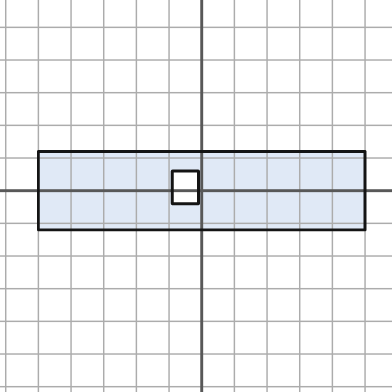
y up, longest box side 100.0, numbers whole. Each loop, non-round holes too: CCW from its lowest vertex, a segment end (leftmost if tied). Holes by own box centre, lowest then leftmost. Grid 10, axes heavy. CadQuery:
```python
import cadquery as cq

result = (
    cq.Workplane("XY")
    .moveTo(-50.0, -12.0)
    .lineTo(50.0, -12.0)
    .lineTo(50.0, 12.0)
    .lineTo(-50.0, 12.0)
    .close()
    .moveTo(-9.0, -4.0)
    .lineTo(-1.0, -4.0)
    .lineTo(-1.0, 6.0)
    .lineTo(-9.0, 6.0)
    .close()
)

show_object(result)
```